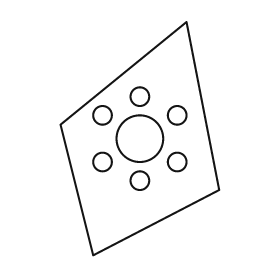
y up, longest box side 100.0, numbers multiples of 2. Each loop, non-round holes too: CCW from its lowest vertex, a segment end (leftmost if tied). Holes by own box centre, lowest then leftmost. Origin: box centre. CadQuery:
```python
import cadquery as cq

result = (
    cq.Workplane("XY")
    .moveTo(-20.0, -50.0)
    .lineTo(34.0, -22.0)
    .lineTo(20.0, 50.0)
    .lineTo(-34.0, 6.0)
    .close()
    .moveTo(0.0, -18.0)
    .circle(4.0)
    .moveTo(-16.0, -10.0)
    .circle(4.0)
    .moveTo(16.0, -10.0)
    .circle(4.0)
    .moveTo(0.0, 0.0)
    .circle(10.0)
    .moveTo(-16.0, 10.0)
    .circle(4.0)
    .moveTo(16.0, 10.0)
    .circle(4.0)
    .moveTo(0.0, 18.0)
    .circle(4.0)
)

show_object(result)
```